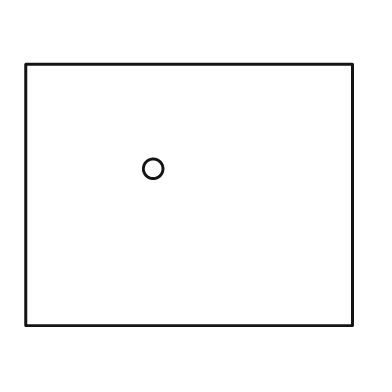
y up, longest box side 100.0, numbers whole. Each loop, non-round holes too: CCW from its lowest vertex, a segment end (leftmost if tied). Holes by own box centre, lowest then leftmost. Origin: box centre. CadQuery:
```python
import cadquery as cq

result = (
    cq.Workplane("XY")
    .moveTo(-50.0, -40.0)
    .lineTo(50.0, -40.0)
    .lineTo(50.0, 40.0)
    .lineTo(-50.0, 40.0)
    .close()
    .moveTo(-11.0, 8.0)
    .circle(3.0)
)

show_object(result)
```